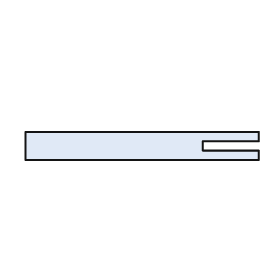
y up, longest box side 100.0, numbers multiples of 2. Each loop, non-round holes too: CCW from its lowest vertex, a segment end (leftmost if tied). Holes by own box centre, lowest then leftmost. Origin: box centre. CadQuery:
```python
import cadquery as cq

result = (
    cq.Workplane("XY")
    .moveTo(-50.0, -6.0)
    .lineTo(50.0, -6.0)
    .lineTo(50.0, -2.0)
    .lineTo(26.0, -2.0)
    .lineTo(26.0, 2.0)
    .lineTo(50.0, 2.0)
    .lineTo(50.0, 6.0)
    .lineTo(-50.0, 6.0)
    .close()
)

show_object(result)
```